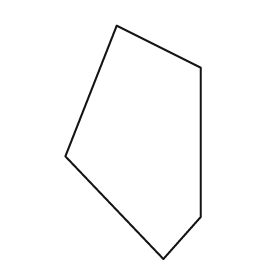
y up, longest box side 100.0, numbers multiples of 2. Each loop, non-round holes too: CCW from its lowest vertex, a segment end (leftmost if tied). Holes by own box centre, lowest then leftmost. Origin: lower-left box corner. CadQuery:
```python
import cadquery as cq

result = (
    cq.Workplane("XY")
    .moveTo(42.0, 0.0)
    .lineTo(58.0, 18.0)
    .lineTo(58.0, 82.0)
    .lineTo(22.0, 100.0)
    .lineTo(0.0, 44.0)
    .close()
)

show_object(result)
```